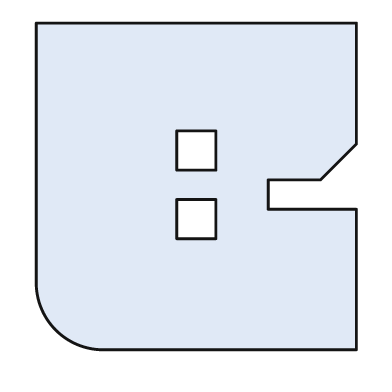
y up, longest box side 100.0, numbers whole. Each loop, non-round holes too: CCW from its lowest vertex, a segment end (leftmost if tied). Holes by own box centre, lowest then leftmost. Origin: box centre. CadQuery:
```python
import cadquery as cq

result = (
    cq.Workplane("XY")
    .moveTo(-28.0, -50.0)
    .lineTo(49.0, -50.0)
    .lineTo(49.0, -7.0)
    .lineTo(22.0, -7.0)
    .lineTo(22.0, 2.0)
    .lineTo(38.0, 2.0)
    .lineTo(49.0, 13.0)
    .lineTo(49.0, 50.0)
    .lineTo(-49.0, 50.0)
    .lineTo(-49.0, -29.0)
    .threePointArc((-43.0, -44.0), (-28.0, -50.0))
    .close()
    .moveTo(-6.0, -16.0)
    .lineTo(6.0, -16.0)
    .lineTo(6.0, -4.0)
    .lineTo(-6.0, -4.0)
    .close()
    .moveTo(-6.0, 5.0)
    .lineTo(6.0, 5.0)
    .lineTo(6.0, 17.0)
    .lineTo(-6.0, 17.0)
    .close()
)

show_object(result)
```